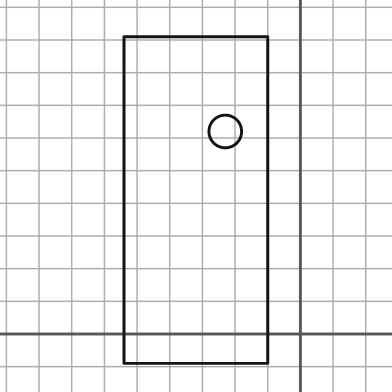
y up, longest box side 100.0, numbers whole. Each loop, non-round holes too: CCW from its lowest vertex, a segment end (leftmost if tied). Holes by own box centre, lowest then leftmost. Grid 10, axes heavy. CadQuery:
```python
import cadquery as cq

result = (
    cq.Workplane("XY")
    .moveTo(-54.0, -9.0)
    .lineTo(-10.0, -9.0)
    .lineTo(-10.0, 91.0)
    .lineTo(-54.0, 91.0)
    .close()
    .moveTo(-23.0, 62.0)
    .circle(5.0)
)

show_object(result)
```